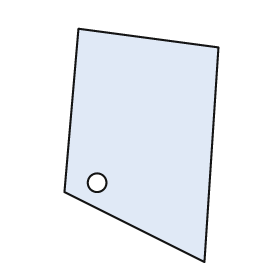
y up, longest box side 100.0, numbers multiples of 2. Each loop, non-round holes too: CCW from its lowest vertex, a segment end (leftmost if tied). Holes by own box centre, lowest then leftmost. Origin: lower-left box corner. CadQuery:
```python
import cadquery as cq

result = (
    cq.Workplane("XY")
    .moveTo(60.0, 0.0)
    .lineTo(66.0, 92.0)
    .lineTo(6.0, 100.0)
    .lineTo(0.0, 30.0)
    .close()
    .moveTo(14.0, 34.0)
    .circle(4.0)
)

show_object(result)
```